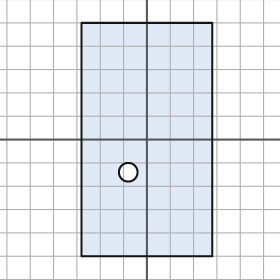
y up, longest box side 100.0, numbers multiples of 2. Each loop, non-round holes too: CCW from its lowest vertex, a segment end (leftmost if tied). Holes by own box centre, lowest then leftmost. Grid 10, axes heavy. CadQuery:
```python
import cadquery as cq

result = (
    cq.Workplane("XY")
    .moveTo(-28.0, -50.0)
    .lineTo(28.0, -50.0)
    .lineTo(28.0, 50.0)
    .lineTo(-28.0, 50.0)
    .close()
    .moveTo(-8.0, -14.0)
    .circle(4.0)
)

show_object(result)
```